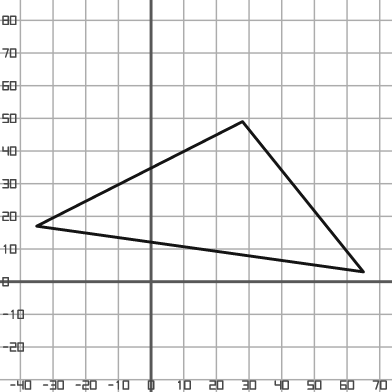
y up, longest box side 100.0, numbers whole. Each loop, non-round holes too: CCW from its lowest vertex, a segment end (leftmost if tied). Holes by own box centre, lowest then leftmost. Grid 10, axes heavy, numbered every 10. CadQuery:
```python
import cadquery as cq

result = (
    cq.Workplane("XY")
    .moveTo(65.0, 3.0)
    .lineTo(28.0, 49.0)
    .lineTo(-35.0, 17.0)
    .close()
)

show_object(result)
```